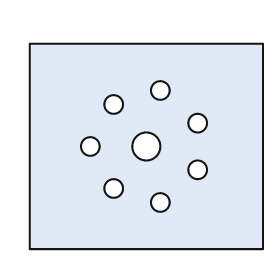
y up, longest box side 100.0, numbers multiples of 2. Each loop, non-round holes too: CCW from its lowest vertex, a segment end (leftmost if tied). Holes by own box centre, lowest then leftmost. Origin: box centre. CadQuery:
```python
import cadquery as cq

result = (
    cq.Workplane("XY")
    .moveTo(-50.0, -44.0)
    .lineTo(50.0, -44.0)
    .lineTo(50.0, 44.0)
    .lineTo(-50.0, 44.0)
    .close()
    .moveTo(6.0, -24.0)
    .circle(4.0)
    .moveTo(-14.0, -18.0)
    .circle(4.0)
    .moveTo(22.0, -10.0)
    .circle(4.0)
    .moveTo(-24.0, 0.0)
    .circle(4.0)
    .moveTo(0.0, 0.0)
    .circle(6.0)
    .moveTo(22.0, 10.0)
    .circle(4.0)
    .moveTo(-14.0, 18.0)
    .circle(4.0)
    .moveTo(6.0, 24.0)
    .circle(4.0)
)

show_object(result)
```